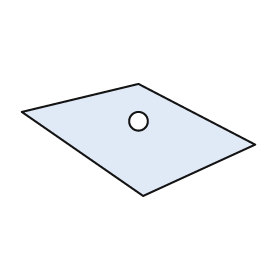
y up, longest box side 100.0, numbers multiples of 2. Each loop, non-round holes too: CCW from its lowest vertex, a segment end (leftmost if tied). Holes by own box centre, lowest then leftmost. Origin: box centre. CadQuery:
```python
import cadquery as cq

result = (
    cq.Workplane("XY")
    .moveTo(2.0, -24.0)
    .lineTo(50.0, -2.0)
    .lineTo(0.0, 24.0)
    .lineTo(-50.0, 12.0)
    .close()
    .moveTo(0.0, 8.0)
    .circle(4.0)
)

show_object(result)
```